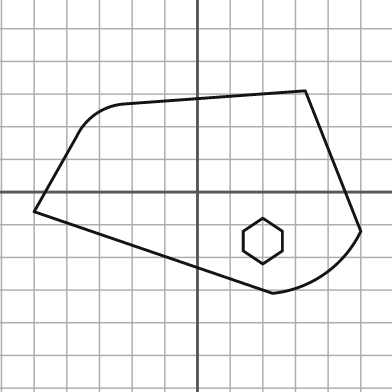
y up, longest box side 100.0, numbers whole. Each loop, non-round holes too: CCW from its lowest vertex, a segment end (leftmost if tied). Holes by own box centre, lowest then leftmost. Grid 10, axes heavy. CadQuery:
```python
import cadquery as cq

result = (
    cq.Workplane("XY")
    .moveTo(23.0, -31.0)
    .threePointArc((39.0, -25.0), (50.0, -12.0))
    .lineTo(33.0, 31.0)
    .lineTo(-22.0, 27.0)
    .threePointArc((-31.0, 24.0), (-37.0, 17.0))
    .lineTo(-50.0, -6.0)
    .close()
    .moveTo(20.0, -22.0)
    .lineTo(26.0, -18.0)
    .lineTo(26.0, -12.0)
    .lineTo(20.0, -8.0)
    .lineTo(14.0, -12.0)
    .lineTo(14.0, -18.0)
    .close()
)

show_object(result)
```